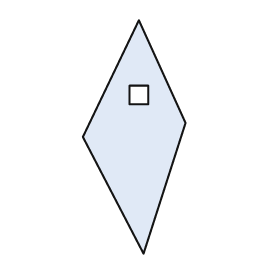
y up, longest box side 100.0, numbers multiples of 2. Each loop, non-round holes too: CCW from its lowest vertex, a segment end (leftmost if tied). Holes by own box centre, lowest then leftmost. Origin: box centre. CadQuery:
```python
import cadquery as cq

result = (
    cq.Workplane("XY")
    .moveTo(4.0, -50.0)
    .lineTo(22.0, 6.0)
    .lineTo(2.0, 50.0)
    .lineTo(-22.0, 0.0)
    .close()
    .moveTo(-2.0, 14.0)
    .lineTo(6.0, 14.0)
    .lineTo(6.0, 22.0)
    .lineTo(-2.0, 22.0)
    .close()
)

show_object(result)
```